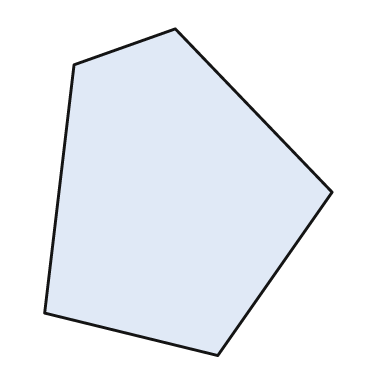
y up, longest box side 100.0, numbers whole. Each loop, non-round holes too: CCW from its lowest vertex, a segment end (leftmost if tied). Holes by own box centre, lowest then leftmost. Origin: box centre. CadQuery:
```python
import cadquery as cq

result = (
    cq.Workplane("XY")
    .moveTo(9.0, -50.0)
    .lineTo(44.0, 0.0)
    .lineTo(-4.0, 50.0)
    .lineTo(-35.0, 39.0)
    .lineTo(-44.0, -37.0)
    .close()
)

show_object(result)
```